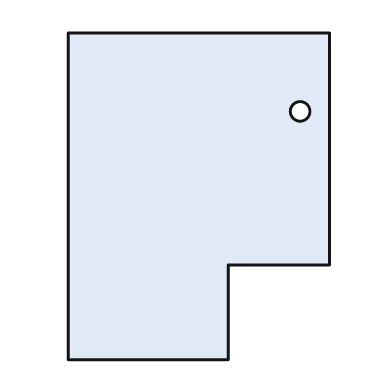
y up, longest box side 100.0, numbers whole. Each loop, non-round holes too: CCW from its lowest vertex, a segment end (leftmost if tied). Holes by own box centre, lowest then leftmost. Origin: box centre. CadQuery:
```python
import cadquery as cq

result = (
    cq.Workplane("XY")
    .moveTo(-40.0, -50.0)
    .lineTo(9.0, -50.0)
    .lineTo(9.0, -21.0)
    .lineTo(40.0, -21.0)
    .lineTo(40.0, 50.0)
    .lineTo(-40.0, 50.0)
    .close()
    .moveTo(31.0, 26.0)
    .circle(3.0)
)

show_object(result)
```